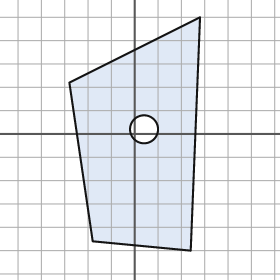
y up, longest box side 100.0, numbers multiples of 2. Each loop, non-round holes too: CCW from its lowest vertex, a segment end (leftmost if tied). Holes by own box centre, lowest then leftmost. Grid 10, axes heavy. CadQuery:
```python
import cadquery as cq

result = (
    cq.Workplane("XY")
    .moveTo(24.0, -50.0)
    .lineTo(28.0, 50.0)
    .lineTo(-28.0, 22.0)
    .lineTo(-18.0, -46.0)
    .close()
    .moveTo(4.0, 2.0)
    .circle(6.0)
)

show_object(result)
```